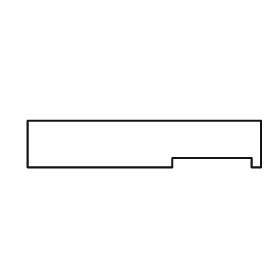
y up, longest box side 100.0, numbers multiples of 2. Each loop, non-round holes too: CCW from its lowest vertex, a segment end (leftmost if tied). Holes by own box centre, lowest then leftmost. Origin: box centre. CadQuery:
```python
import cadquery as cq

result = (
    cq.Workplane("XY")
    .moveTo(-50.0, -10.0)
    .lineTo(12.0, -10.0)
    .lineTo(12.0, -6.0)
    .lineTo(46.0, -6.0)
    .lineTo(46.0, -10.0)
    .lineTo(50.0, -10.0)
    .lineTo(50.0, 10.0)
    .lineTo(-50.0, 10.0)
    .close()
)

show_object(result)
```